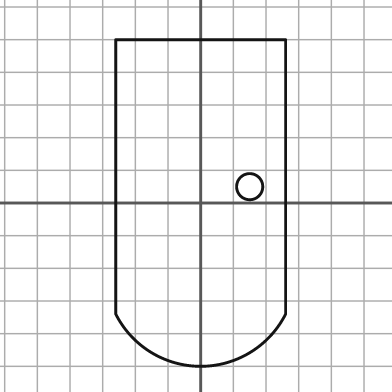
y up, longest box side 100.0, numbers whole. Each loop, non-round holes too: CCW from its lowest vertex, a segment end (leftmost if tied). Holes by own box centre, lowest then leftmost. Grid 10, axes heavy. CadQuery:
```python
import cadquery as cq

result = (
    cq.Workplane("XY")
    .moveTo(-26.0, -34.0)
    .threePointArc((0.0, -50.0), (26.0, -34.0))
    .lineTo(26.0, 50.0)
    .lineTo(-26.0, 50.0)
    .close()
    .moveTo(15.0, 5.0)
    .circle(4.0)
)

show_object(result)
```